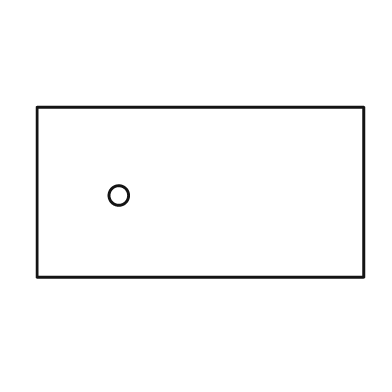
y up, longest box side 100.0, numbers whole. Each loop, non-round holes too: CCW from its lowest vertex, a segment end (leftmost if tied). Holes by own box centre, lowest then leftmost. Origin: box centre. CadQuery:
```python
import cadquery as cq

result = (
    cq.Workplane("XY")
    .moveTo(-50.0, -26.0)
    .lineTo(50.0, -26.0)
    .lineTo(50.0, 26.0)
    .lineTo(-50.0, 26.0)
    .close()
    .moveTo(-25.0, -1.0)
    .circle(3.0)
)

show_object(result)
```